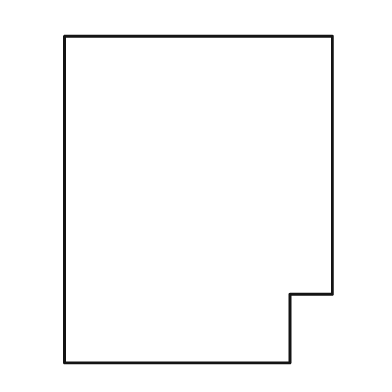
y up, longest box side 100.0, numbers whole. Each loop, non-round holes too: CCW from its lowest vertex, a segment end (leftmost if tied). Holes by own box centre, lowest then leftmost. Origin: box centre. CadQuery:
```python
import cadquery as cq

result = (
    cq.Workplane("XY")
    .moveTo(-41.0, -50.0)
    .lineTo(28.0, -50.0)
    .lineTo(28.0, -29.0)
    .lineTo(41.0, -29.0)
    .lineTo(41.0, 50.0)
    .lineTo(-41.0, 50.0)
    .close()
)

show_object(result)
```